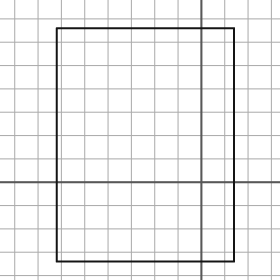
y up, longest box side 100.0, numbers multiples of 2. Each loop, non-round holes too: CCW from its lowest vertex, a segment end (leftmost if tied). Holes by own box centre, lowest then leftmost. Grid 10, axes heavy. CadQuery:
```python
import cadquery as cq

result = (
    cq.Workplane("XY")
    .moveTo(-62.0, -34.0)
    .lineTo(14.0, -34.0)
    .lineTo(14.0, 66.0)
    .lineTo(-62.0, 66.0)
    .close()
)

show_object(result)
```